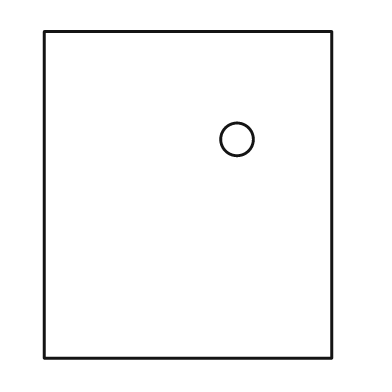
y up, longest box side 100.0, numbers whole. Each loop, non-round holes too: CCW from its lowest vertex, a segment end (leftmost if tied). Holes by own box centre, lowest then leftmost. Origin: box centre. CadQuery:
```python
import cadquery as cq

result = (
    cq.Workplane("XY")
    .moveTo(-44.0, -50.0)
    .lineTo(44.0, -50.0)
    .lineTo(44.0, 50.0)
    .lineTo(-44.0, 50.0)
    .close()
    .moveTo(15.0, 17.0)
    .circle(5.0)
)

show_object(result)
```